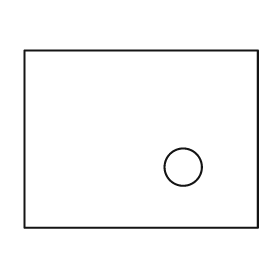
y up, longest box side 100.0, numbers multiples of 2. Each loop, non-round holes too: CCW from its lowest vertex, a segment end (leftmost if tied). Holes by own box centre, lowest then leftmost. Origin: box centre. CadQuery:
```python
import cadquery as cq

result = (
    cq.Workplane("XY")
    .moveTo(-50.0, -38.0)
    .lineTo(50.0, -38.0)
    .lineTo(50.0, 38.0)
    .lineTo(-50.0, 38.0)
    .close()
    .moveTo(18.0, -12.0)
    .circle(8.0)
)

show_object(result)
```